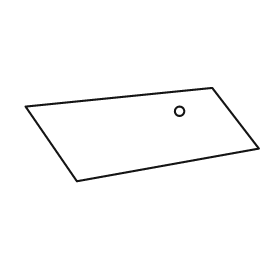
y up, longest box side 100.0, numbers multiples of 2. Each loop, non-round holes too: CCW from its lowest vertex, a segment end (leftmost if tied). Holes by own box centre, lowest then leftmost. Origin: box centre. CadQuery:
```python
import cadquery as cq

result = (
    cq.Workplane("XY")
    .moveTo(-28.0, -20.0)
    .lineTo(50.0, -6.0)
    .lineTo(30.0, 20.0)
    .lineTo(-50.0, 12.0)
    .close()
    .moveTo(16.0, 10.0)
    .circle(2.0)
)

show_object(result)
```